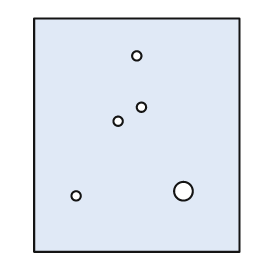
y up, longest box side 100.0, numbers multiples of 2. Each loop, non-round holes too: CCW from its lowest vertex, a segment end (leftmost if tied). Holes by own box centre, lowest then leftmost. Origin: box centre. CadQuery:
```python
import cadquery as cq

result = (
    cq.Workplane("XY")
    .moveTo(-44.0, -50.0)
    .lineTo(44.0, -50.0)
    .lineTo(44.0, 50.0)
    .lineTo(-44.0, 50.0)
    .close()
    .moveTo(-26.0, -26.0)
    .circle(2.0)
    .moveTo(20.0, -24.0)
    .circle(4.0)
    .moveTo(-8.0, 6.0)
    .circle(2.0)
    .moveTo(2.0, 12.0)
    .circle(2.0)
    .moveTo(0.0, 34.0)
    .circle(2.0)
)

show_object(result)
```